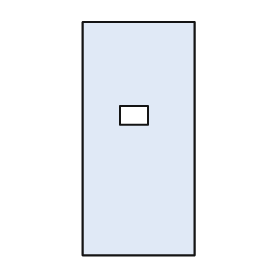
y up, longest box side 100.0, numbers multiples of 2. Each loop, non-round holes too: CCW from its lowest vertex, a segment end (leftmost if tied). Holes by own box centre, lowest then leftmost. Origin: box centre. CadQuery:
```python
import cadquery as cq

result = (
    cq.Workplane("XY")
    .moveTo(-24.0, -50.0)
    .lineTo(24.0, -50.0)
    .lineTo(24.0, 50.0)
    .lineTo(-24.0, 50.0)
    .close()
    .moveTo(-8.0, 6.0)
    .lineTo(4.0, 6.0)
    .lineTo(4.0, 14.0)
    .lineTo(-8.0, 14.0)
    .close()
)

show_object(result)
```